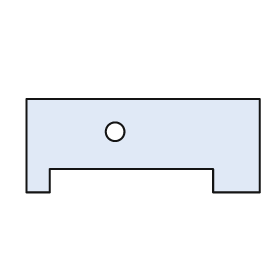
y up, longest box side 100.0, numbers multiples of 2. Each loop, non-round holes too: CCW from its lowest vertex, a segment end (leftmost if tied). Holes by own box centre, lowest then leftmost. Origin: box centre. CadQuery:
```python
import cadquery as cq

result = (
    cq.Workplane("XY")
    .moveTo(-50.0, -20.0)
    .lineTo(-40.0, -20.0)
    .lineTo(-40.0, -10.0)
    .lineTo(30.0, -10.0)
    .lineTo(30.0, -20.0)
    .lineTo(50.0, -20.0)
    .lineTo(50.0, 20.0)
    .lineTo(-50.0, 20.0)
    .close()
    .moveTo(-12.0, 6.0)
    .circle(4.0)
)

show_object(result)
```